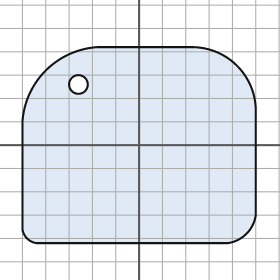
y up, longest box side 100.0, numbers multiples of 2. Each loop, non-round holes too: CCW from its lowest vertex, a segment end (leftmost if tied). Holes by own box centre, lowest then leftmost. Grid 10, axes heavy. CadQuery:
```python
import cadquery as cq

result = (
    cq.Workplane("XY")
    .moveTo(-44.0, -42.0)
    .lineTo(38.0, -42.0)
    .threePointArc((46.0, -38.0), (50.0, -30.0))
    .lineTo(50.0, 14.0)
    .threePointArc((42.0, 34.0), (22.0, 42.0))
    .lineTo(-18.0, 42.0)
    .threePointArc((-40.0, 32.0), (-50.0, 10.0))
    .lineTo(-50.0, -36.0)
    .threePointArc((-48.0, -40.0), (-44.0, -42.0))
    .close()
    .moveTo(-26.0, 26.0)
    .circle(4.0)
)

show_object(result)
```